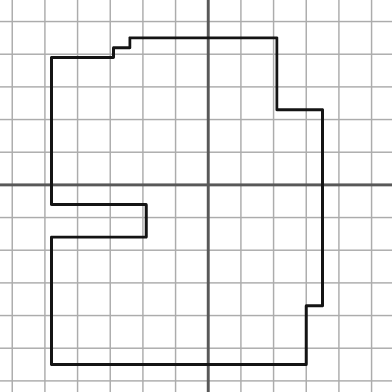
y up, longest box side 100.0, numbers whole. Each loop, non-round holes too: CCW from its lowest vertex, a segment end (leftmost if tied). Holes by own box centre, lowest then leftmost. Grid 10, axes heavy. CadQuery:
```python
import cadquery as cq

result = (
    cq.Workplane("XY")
    .moveTo(-48.0, -55.0)
    .lineTo(30.0, -55.0)
    .lineTo(30.0, -37.0)
    .lineTo(35.0, -37.0)
    .lineTo(35.0, 23.0)
    .lineTo(21.0, 23.0)
    .lineTo(21.0, 45.0)
    .lineTo(-24.0, 45.0)
    .lineTo(-24.0, 42.0)
    .lineTo(-29.0, 42.0)
    .lineTo(-29.0, 39.0)
    .lineTo(-48.0, 39.0)
    .lineTo(-48.0, -6.0)
    .lineTo(-19.0, -6.0)
    .lineTo(-19.0, -16.0)
    .lineTo(-48.0, -16.0)
    .close()
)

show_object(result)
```